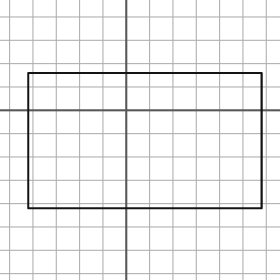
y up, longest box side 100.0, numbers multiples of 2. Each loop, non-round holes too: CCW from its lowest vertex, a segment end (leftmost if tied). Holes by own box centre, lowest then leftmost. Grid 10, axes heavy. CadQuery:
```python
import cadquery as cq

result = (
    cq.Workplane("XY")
    .moveTo(-42.0, -42.0)
    .lineTo(58.0, -42.0)
    .lineTo(58.0, 16.0)
    .lineTo(-42.0, 16.0)
    .close()
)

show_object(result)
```